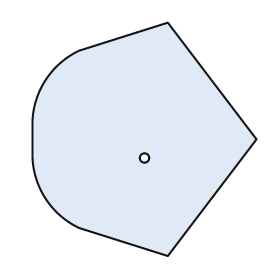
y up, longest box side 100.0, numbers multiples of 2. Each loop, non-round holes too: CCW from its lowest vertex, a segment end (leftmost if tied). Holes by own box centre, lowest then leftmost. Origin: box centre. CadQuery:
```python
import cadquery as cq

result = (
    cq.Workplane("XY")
    .moveTo(10.0, -50.0)
    .lineTo(48.0, 0.0)
    .lineTo(10.0, 50.0)
    .lineTo(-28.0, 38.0)
    .threePointArc((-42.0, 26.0), (-48.0, 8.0))
    .lineTo(-48.0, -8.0)
    .threePointArc((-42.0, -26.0), (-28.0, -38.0))
    .close()
    .moveTo(0.0, -8.0)
    .circle(2.0)
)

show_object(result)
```